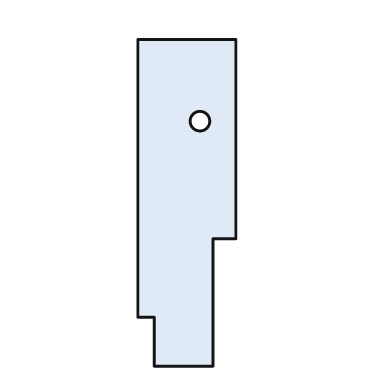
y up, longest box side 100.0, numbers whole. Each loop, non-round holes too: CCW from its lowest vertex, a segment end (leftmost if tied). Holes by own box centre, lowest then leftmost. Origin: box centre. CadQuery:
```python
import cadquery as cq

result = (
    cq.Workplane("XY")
    .moveTo(-10.0, -50.0)
    .lineTo(8.0, -50.0)
    .lineTo(8.0, -11.0)
    .lineTo(15.0, -11.0)
    .lineTo(15.0, 50.0)
    .lineTo(-15.0, 50.0)
    .lineTo(-15.0, -35.0)
    .lineTo(-10.0, -35.0)
    .close()
    .moveTo(4.0, 25.0)
    .circle(3.0)
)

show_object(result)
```